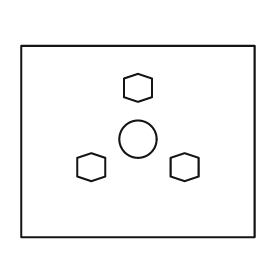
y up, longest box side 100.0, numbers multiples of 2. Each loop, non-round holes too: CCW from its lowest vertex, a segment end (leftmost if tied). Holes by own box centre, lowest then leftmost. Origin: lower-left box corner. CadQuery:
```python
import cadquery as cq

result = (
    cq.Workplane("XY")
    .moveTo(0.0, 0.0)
    .lineTo(100.0, 0.0)
    .lineTo(100.0, 82.0)
    .lineTo(0.0, 82.0)
    .close()
    .moveTo(30.0, 24.0)
    .lineTo(36.0, 26.0)
    .lineTo(36.0, 34.0)
    .lineTo(30.0, 36.0)
    .lineTo(24.0, 34.0)
    .lineTo(24.0, 26.0)
    .close()
    .moveTo(70.0, 24.0)
    .lineTo(76.0, 26.0)
    .lineTo(76.0, 34.0)
    .lineTo(70.0, 36.0)
    .lineTo(64.0, 34.0)
    .lineTo(64.0, 26.0)
    .close()
    .moveTo(50.0, 42.0)
    .circle(8.0)
    .moveTo(50.0, 58.0)
    .lineTo(56.0, 60.0)
    .lineTo(56.0, 68.0)
    .lineTo(50.0, 70.0)
    .lineTo(44.0, 68.0)
    .lineTo(44.0, 60.0)
    .close()
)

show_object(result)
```